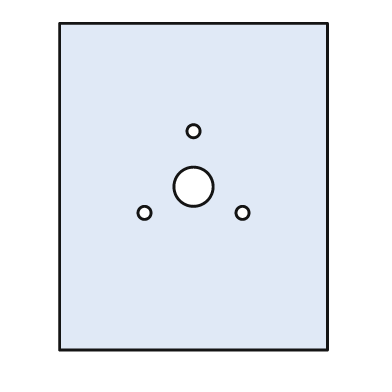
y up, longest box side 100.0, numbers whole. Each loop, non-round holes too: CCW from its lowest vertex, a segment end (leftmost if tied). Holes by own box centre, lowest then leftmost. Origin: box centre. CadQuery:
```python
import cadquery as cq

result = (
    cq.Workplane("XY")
    .moveTo(-41.0, -50.0)
    .lineTo(41.0, -50.0)
    .lineTo(41.0, 50.0)
    .lineTo(-41.0, 50.0)
    .close()
    .moveTo(-15.0, -8.0)
    .circle(2.0)
    .moveTo(15.0, -8.0)
    .circle(2.0)
    .moveTo(0.0, 0.0)
    .circle(6.0)
    .moveTo(0.0, 17.0)
    .circle(2.0)
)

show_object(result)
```